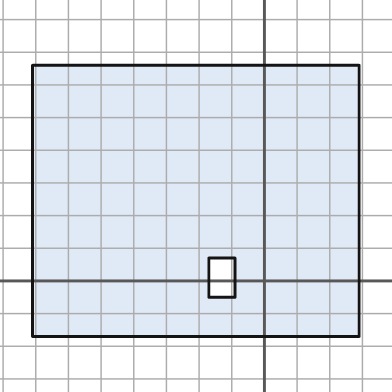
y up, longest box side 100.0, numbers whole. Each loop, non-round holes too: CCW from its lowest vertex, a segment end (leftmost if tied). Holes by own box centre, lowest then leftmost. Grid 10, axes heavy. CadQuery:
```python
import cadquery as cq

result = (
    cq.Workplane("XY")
    .moveTo(-71.0, -17.0)
    .lineTo(29.0, -17.0)
    .lineTo(29.0, 66.0)
    .lineTo(-71.0, 66.0)
    .close()
    .moveTo(-17.0, -5.0)
    .lineTo(-9.0, -5.0)
    .lineTo(-9.0, 7.0)
    .lineTo(-17.0, 7.0)
    .close()
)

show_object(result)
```